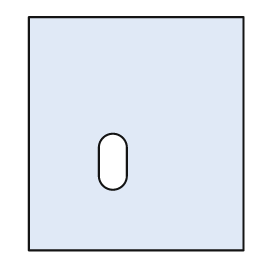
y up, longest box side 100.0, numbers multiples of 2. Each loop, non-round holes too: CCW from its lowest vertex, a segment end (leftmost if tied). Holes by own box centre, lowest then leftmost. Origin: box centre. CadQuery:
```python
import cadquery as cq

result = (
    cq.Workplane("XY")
    .moveTo(-46.0, -50.0)
    .lineTo(46.0, -50.0)
    .lineTo(46.0, 50.0)
    .lineTo(-46.0, 50.0)
    .close()
    .moveTo(-16.0, -18.0)
    .threePointArc((-10.0, -24.0), (-4.0, -18.0))
    .lineTo(-4.0, -6.0)
    .threePointArc((-10.0, 0.0), (-16.0, -6.0))
    .close()
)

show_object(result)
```